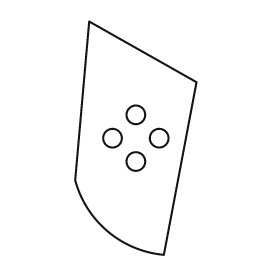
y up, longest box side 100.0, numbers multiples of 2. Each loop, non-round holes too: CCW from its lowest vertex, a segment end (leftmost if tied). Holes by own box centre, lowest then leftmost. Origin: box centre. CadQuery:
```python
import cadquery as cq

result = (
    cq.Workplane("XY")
    .moveTo(12.0, -50.0)
    .lineTo(26.0, 24.0)
    .lineTo(-20.0, 50.0)
    .lineTo(-26.0, -18.0)
    .threePointArc((-12.0, -40.0), (12.0, -50.0))
    .close()
    .moveTo(0.0, -10.0)
    .circle(4.0)
    .moveTo(-10.0, 0.0)
    .circle(4.0)
    .moveTo(10.0, 0.0)
    .circle(4.0)
    .moveTo(0.0, 10.0)
    .circle(4.0)
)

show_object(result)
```